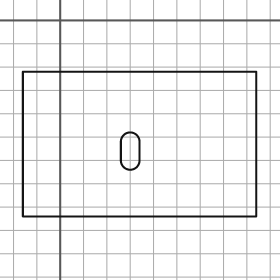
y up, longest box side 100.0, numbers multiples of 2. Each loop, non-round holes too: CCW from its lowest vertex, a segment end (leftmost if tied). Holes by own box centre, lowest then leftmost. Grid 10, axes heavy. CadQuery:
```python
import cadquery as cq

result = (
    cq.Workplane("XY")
    .moveTo(-16.0, -84.0)
    .lineTo(84.0, -84.0)
    .lineTo(84.0, -22.0)
    .lineTo(-16.0, -22.0)
    .close()
    .moveTo(26.0, -60.0)
    .threePointArc((30.0, -64.0), (34.0, -60.0))
    .lineTo(34.0, -52.0)
    .threePointArc((30.0, -48.0), (26.0, -52.0))
    .close()
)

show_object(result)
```